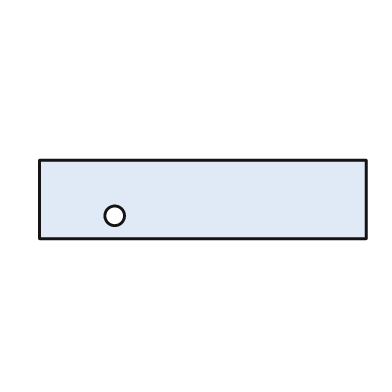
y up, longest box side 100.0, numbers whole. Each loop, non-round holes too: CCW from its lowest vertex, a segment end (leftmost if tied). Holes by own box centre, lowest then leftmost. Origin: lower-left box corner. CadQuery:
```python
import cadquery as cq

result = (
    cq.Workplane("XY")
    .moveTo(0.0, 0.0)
    .lineTo(100.0, 0.0)
    .lineTo(100.0, 24.0)
    .lineTo(0.0, 24.0)
    .close()
    .moveTo(23.0, 7.0)
    .circle(3.0)
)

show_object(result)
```